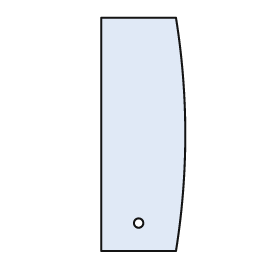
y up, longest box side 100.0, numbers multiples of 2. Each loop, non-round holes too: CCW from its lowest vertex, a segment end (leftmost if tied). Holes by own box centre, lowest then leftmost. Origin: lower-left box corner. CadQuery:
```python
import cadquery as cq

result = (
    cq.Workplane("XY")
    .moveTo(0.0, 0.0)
    .lineTo(32.0, 0.0)
    .threePointArc((36.0, 50.0), (32.0, 100.0))
    .lineTo(0.0, 100.0)
    .close()
    .moveTo(16.0, 12.0)
    .circle(2.0)
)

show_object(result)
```